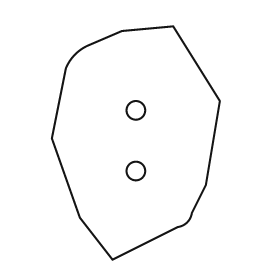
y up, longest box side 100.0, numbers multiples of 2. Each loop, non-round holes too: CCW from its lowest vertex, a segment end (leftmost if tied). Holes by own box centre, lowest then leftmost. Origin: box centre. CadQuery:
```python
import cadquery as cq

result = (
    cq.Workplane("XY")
    .moveTo(-10.0, -50.0)
    .lineTo(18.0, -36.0)
    .threePointArc((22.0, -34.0), (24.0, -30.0))
    .lineTo(30.0, -18.0)
    .lineTo(36.0, 18.0)
    .lineTo(16.0, 50.0)
    .lineTo(-6.0, 48.0)
    .lineTo(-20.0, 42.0)
    .threePointArc((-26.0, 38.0), (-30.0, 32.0))
    .lineTo(-36.0, 2.0)
    .lineTo(-24.0, -32.0)
    .close()
    .moveTo(0.0, -12.0)
    .circle(4.0)
    .moveTo(0.0, 14.0)
    .circle(4.0)
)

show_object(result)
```